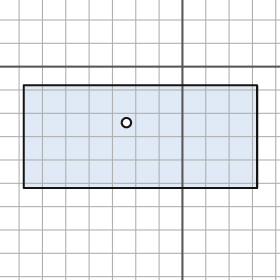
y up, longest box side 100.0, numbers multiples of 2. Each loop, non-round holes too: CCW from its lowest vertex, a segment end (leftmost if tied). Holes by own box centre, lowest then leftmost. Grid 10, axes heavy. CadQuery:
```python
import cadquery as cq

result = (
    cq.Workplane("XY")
    .moveTo(-68.0, -52.0)
    .lineTo(32.0, -52.0)
    .lineTo(32.0, -8.0)
    .lineTo(-68.0, -8.0)
    .close()
    .moveTo(-24.0, -24.0)
    .circle(2.0)
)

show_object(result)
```